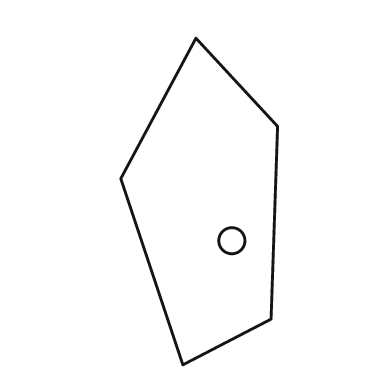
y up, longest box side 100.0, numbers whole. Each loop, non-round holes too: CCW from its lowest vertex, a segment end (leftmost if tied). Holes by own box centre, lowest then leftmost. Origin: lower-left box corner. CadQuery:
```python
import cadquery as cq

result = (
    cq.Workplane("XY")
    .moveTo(19.0, 0.0)
    .lineTo(46.0, 14.0)
    .lineTo(48.0, 73.0)
    .lineTo(23.0, 100.0)
    .lineTo(0.0, 57.0)
    .close()
    .moveTo(34.0, 38.0)
    .circle(4.0)
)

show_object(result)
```